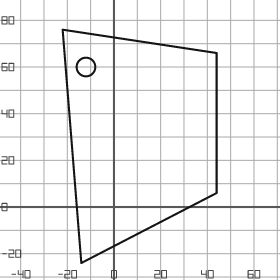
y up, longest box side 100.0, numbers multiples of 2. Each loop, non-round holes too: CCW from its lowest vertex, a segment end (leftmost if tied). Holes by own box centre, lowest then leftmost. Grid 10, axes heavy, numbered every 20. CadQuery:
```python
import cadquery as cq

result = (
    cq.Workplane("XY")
    .moveTo(-14.0, -24.0)
    .lineTo(44.0, 6.0)
    .lineTo(44.0, 66.0)
    .lineTo(-22.0, 76.0)
    .close()
    .moveTo(-12.0, 60.0)
    .circle(4.0)
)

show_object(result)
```